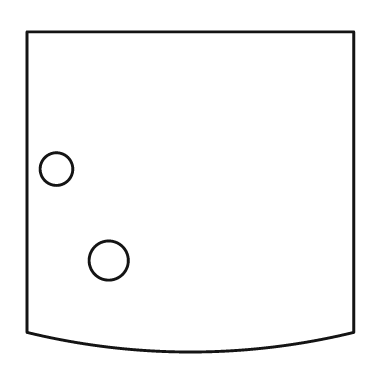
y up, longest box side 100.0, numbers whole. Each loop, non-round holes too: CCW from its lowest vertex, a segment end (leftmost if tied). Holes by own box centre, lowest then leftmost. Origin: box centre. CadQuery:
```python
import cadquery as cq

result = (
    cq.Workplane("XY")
    .moveTo(-50.0, -43.0)
    .threePointArc((0.0, -49.0), (50.0, -43.0))
    .lineTo(50.0, 49.0)
    .lineTo(-50.0, 49.0)
    .close()
    .moveTo(-25.0, -21.0)
    .circle(6.0)
    .moveTo(-41.0, 7.0)
    .circle(5.0)
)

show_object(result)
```